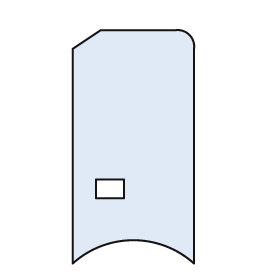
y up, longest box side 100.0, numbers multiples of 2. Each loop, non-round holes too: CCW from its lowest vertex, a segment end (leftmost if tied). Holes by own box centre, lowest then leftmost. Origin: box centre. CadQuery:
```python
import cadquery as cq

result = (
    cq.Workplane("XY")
    .moveTo(-26.0, -50.0)
    .threePointArc((0.0, -40.0), (26.0, -50.0))
    .lineTo(26.0, 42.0)
    .threePointArc((24.0, 48.0), (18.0, 50.0))
    .lineTo(-14.0, 50.0)
    .lineTo(-26.0, 42.0)
    .close()
    .moveTo(-16.0, -22.0)
    .lineTo(-4.0, -22.0)
    .lineTo(-4.0, -14.0)
    .lineTo(-16.0, -14.0)
    .close()
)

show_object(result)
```